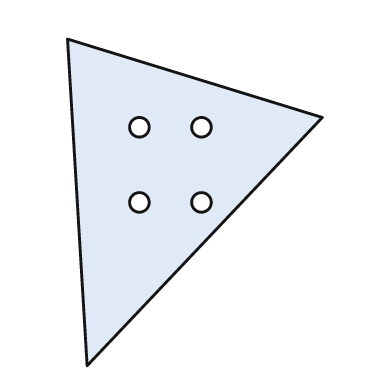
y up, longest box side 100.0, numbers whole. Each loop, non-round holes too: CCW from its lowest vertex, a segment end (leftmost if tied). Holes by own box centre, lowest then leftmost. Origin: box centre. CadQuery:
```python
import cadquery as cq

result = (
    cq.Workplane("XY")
    .moveTo(-33.0, -50.0)
    .lineTo(39.0, 26.0)
    .lineTo(-39.0, 50.0)
    .close()
    .moveTo(-17.0, 0.0)
    .circle(3.0)
    .moveTo(2.0, 0.0)
    .circle(3.0)
    .moveTo(-17.0, 23.0)
    .circle(3.0)
    .moveTo(2.0, 23.0)
    .circle(3.0)
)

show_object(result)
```